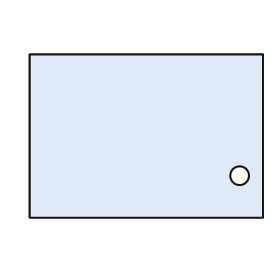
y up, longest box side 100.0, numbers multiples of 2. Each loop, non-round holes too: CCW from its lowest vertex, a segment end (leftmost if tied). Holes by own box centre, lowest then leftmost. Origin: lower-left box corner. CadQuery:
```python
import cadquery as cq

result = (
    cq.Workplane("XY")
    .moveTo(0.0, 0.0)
    .lineTo(100.0, 0.0)
    .lineTo(100.0, 70.0)
    .lineTo(0.0, 70.0)
    .close()
    .moveTo(90.0, 18.0)
    .circle(4.0)
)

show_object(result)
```